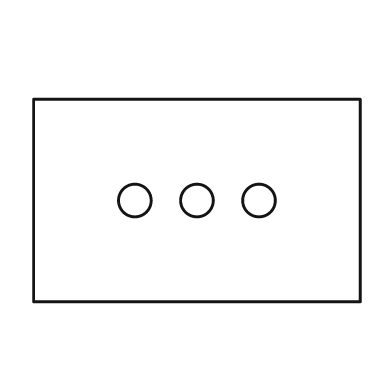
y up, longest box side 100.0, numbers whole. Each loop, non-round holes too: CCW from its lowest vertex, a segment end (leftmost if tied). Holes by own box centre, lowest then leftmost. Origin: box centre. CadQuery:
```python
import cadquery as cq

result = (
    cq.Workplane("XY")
    .moveTo(-50.0, -31.0)
    .lineTo(50.0, -31.0)
    .lineTo(50.0, 31.0)
    .lineTo(-50.0, 31.0)
    .close()
    .moveTo(-19.0, 0.0)
    .circle(5.0)
    .moveTo(0.0, 0.0)
    .circle(5.0)
    .moveTo(19.0, 0.0)
    .circle(5.0)
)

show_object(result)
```